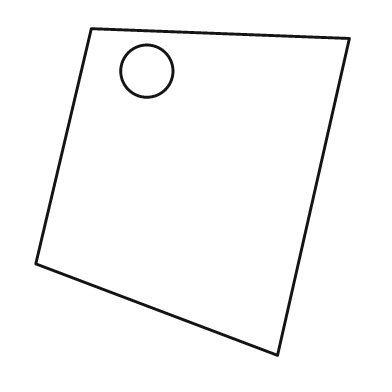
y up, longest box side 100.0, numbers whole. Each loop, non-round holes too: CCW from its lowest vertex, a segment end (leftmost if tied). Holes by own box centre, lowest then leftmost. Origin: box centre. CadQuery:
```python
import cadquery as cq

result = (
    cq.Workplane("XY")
    .moveTo(26.0, -50.0)
    .lineTo(48.0, 47.0)
    .lineTo(-31.0, 50.0)
    .lineTo(-48.0, -22.0)
    .close()
    .moveTo(-14.0, 37.0)
    .circle(8.0)
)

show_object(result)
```